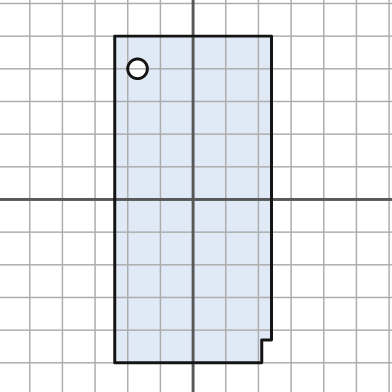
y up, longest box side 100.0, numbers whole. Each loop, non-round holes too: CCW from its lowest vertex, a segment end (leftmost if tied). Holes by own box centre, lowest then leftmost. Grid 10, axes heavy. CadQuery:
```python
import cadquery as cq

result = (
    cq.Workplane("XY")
    .moveTo(-24.0, -50.0)
    .lineTo(21.0, -50.0)
    .lineTo(21.0, -43.0)
    .lineTo(24.0, -43.0)
    .lineTo(24.0, 50.0)
    .lineTo(-24.0, 50.0)
    .close()
    .moveTo(-17.0, 40.0)
    .circle(3.0)
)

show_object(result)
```